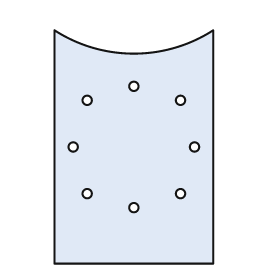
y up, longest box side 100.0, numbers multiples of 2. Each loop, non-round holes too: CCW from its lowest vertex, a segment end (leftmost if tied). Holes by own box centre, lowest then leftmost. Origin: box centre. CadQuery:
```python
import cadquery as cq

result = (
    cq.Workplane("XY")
    .moveTo(-34.0, -50.0)
    .lineTo(34.0, -50.0)
    .lineTo(34.0, 50.0)
    .threePointArc((0.0, 40.0), (-34.0, 50.0))
    .close()
    .moveTo(0.0, -26.0)
    .circle(2.0)
    .moveTo(-20.0, -20.0)
    .circle(2.0)
    .moveTo(20.0, -20.0)
    .circle(2.0)
    .moveTo(-26.0, 0.0)
    .circle(2.0)
    .moveTo(26.0, 0.0)
    .circle(2.0)
    .moveTo(-20.0, 20.0)
    .circle(2.0)
    .moveTo(20.0, 20.0)
    .circle(2.0)
    .moveTo(0.0, 26.0)
    .circle(2.0)
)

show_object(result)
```